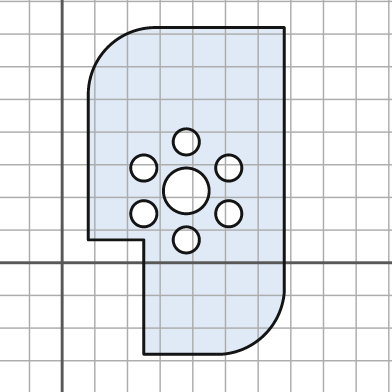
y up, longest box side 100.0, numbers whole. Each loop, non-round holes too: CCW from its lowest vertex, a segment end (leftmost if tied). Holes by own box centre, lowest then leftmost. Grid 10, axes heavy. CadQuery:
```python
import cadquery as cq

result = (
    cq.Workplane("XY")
    .moveTo(25.0, -28.0)
    .lineTo(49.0, -28.0)
    .threePointArc((62.0, -22.0), (68.0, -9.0))
    .lineTo(68.0, 72.0)
    .lineTo(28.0, 72.0)
    .threePointArc((14.0, 66.0), (8.0, 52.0))
    .lineTo(8.0, 7.0)
    .lineTo(25.0, 7.0)
    .close()
    .moveTo(38.0, 7.0)
    .circle(4.0)
    .moveTo(25.0, 15.0)
    .circle(4.0)
    .moveTo(51.0, 15.0)
    .circle(4.0)
    .moveTo(38.0, 22.0)
    .circle(7.0)
    .moveTo(25.0, 29.0)
    .circle(4.0)
    .moveTo(51.0, 29.0)
    .circle(4.0)
    .moveTo(38.0, 37.0)
    .circle(4.0)
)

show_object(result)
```